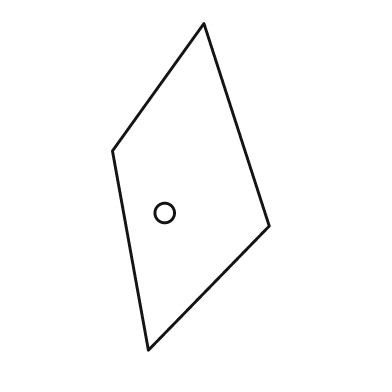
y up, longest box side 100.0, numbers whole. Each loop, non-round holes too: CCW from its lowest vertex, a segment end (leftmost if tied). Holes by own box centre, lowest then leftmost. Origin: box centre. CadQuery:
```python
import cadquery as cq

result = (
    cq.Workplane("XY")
    .moveTo(-13.0, -50.0)
    .lineTo(24.0, -12.0)
    .lineTo(4.0, 50.0)
    .lineTo(-24.0, 11.0)
    .close()
    .moveTo(-8.0, -8.0)
    .circle(3.0)
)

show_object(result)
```